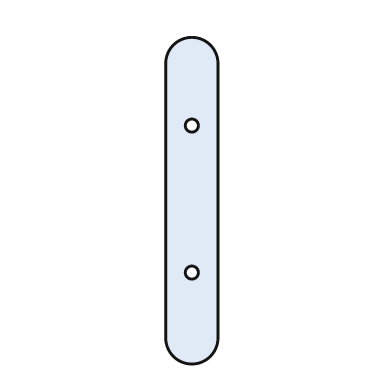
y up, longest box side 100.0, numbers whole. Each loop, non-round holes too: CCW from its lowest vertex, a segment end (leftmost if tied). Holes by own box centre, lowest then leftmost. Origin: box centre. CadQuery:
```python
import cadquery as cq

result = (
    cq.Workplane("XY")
    .moveTo(-8.0, -42.0)
    .threePointArc((0.0, -50.0), (8.0, -42.0))
    .lineTo(8.0, 42.0)
    .threePointArc((0.0, 50.0), (-8.0, 42.0))
    .close()
    .moveTo(0.0, -22.0)
    .circle(2.0)
    .moveTo(0.0, 23.0)
    .circle(2.0)
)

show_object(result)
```